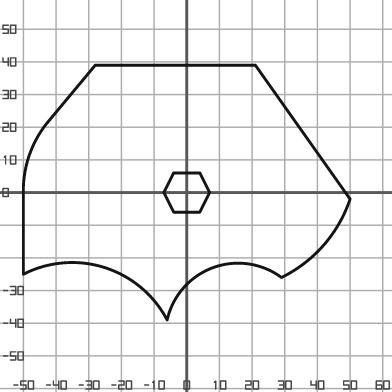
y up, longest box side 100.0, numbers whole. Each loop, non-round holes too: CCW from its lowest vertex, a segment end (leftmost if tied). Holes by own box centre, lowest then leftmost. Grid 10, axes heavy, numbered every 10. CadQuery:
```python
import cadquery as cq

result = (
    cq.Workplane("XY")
    .moveTo(-6.0, -39.0)
    .threePointArc((8.0, -23.0), (29.0, -26.0))
    .threePointArc((42.0, -16.0), (50.0, -2.0))
    .lineTo(21.0, 39.0)
    .lineTo(-28.0, 39.0)
    .lineTo(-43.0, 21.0)
    .threePointArc((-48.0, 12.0), (-50.0, 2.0))
    .lineTo(-50.0, -25.0)
    .threePointArc((-25.0, -23.0), (-6.0, -39.0))
    .close()
    .moveTo(-4.0, -6.0)
    .lineTo(4.0, -6.0)
    .lineTo(7.0, 0.0)
    .lineTo(4.0, 6.0)
    .lineTo(-4.0, 6.0)
    .lineTo(-7.0, 0.0)
    .close()
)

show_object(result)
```